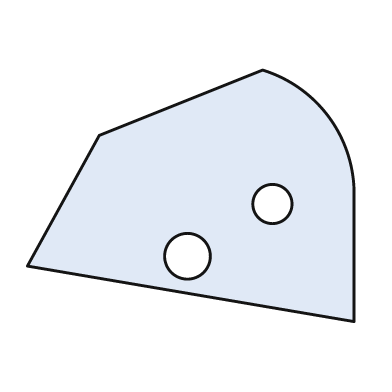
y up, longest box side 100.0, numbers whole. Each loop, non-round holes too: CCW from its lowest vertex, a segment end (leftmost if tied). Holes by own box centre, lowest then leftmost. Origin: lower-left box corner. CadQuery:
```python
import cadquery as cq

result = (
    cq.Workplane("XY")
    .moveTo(100.0, 0.0)
    .lineTo(100.0, 40.0)
    .threePointArc((92.0, 63.0), (72.0, 77.0))
    .lineTo(22.0, 57.0)
    .lineTo(0.0, 17.0)
    .close()
    .moveTo(49.0, 20.0)
    .circle(7.0)
    .moveTo(75.0, 36.0)
    .circle(6.0)
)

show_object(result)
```